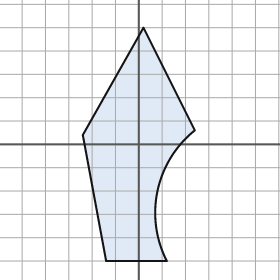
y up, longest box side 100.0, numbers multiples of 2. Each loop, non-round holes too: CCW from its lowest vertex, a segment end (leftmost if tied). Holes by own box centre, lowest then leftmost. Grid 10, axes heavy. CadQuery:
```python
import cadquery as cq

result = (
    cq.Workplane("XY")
    .moveTo(-14.0, -50.0)
    .lineTo(12.0, -50.0)
    .threePointArc((8.0, -20.0), (24.0, 6.0))
    .lineTo(2.0, 50.0)
    .lineTo(-24.0, 4.0)
    .close()
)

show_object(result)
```